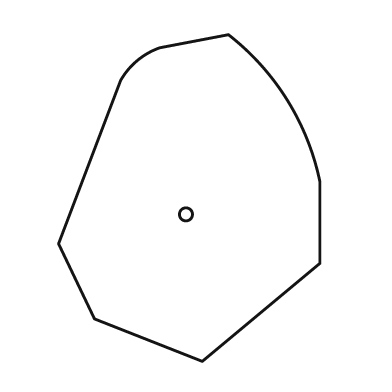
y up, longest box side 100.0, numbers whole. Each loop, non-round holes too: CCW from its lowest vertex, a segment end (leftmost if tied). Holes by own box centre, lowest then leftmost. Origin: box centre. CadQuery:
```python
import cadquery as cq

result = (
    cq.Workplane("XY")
    .moveTo(4.0, -50.0)
    .lineTo(40.0, -20.0)
    .lineTo(40.0, 5.0)
    .threePointArc((30.0, 30.0), (12.0, 50.0))
    .lineTo(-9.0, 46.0)
    .threePointArc((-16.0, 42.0), (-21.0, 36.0))
    .lineTo(-40.0, -14.0)
    .lineTo(-29.0, -37.0)
    .close()
    .moveTo(-1.0, -5.0)
    .circle(2.0)
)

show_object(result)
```